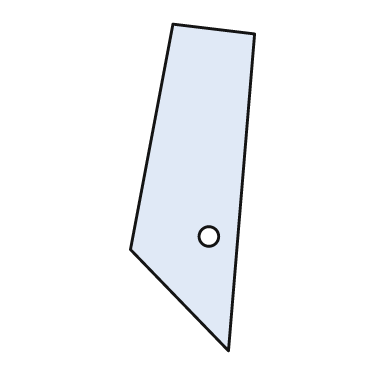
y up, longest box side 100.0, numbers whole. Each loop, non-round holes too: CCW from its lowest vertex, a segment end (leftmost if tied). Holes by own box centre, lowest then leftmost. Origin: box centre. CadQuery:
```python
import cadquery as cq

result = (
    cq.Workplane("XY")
    .moveTo(11.0, -50.0)
    .lineTo(19.0, 47.0)
    .lineTo(-6.0, 50.0)
    .lineTo(-19.0, -19.0)
    .close()
    .moveTo(5.0, -15.0)
    .circle(3.0)
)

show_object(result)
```